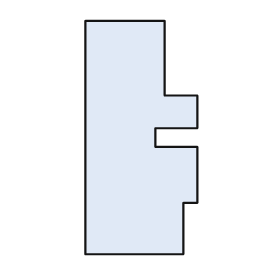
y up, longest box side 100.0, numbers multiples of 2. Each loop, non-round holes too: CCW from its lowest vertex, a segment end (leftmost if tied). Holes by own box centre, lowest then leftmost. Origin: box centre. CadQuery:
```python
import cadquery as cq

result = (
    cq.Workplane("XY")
    .moveTo(-24.0, -50.0)
    .lineTo(18.0, -50.0)
    .lineTo(18.0, -28.0)
    .lineTo(24.0, -28.0)
    .lineTo(24.0, -4.0)
    .lineTo(6.0, -4.0)
    .lineTo(6.0, 4.0)
    .lineTo(24.0, 4.0)
    .lineTo(24.0, 18.0)
    .lineTo(10.0, 18.0)
    .lineTo(10.0, 50.0)
    .lineTo(-24.0, 50.0)
    .close()
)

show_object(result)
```